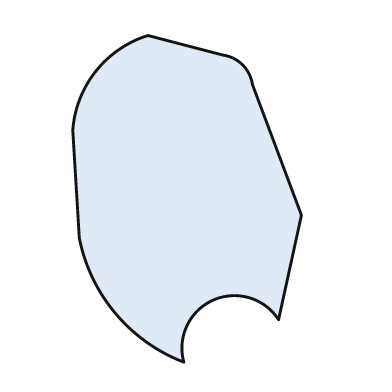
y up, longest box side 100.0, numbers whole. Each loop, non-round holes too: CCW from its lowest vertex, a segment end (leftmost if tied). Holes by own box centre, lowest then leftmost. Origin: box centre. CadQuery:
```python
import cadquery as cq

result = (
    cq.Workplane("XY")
    .moveTo(-1.0, -50.0)
    .threePointArc((8.0, -31.0), (28.0, -37.0))
    .lineTo(35.0, -5.0)
    .lineTo(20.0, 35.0)
    .threePointArc((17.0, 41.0), (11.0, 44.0))
    .lineTo(-12.0, 50.0)
    .threePointArc((-28.0, 39.0), (-35.0, 21.0))
    .lineTo(-33.0, -12.0)
    .threePointArc((-22.0, -35.0), (-1.0, -50.0))
    .close()
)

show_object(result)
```